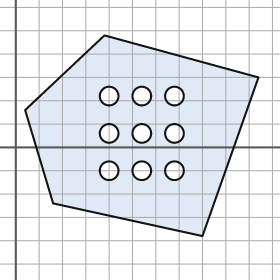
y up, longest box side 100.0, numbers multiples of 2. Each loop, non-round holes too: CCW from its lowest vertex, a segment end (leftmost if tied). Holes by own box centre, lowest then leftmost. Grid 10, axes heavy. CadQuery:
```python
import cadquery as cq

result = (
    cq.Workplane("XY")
    .moveTo(80.0, -38.0)
    .lineTo(104.0, 30.0)
    .lineTo(38.0, 48.0)
    .lineTo(4.0, 16.0)
    .lineTo(16.0, -24.0)
    .close()
    .moveTo(40.0, -10.0)
    .circle(4.0)
    .moveTo(54.0, -10.0)
    .circle(4.0)
    .moveTo(68.0, -10.0)
    .circle(4.0)
    .moveTo(40.0, 6.0)
    .circle(4.0)
    .moveTo(54.0, 6.0)
    .circle(4.0)
    .moveTo(68.0, 6.0)
    .circle(4.0)
    .moveTo(40.0, 22.0)
    .circle(4.0)
    .moveTo(54.0, 22.0)
    .circle(4.0)
    .moveTo(68.0, 22.0)
    .circle(4.0)
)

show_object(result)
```